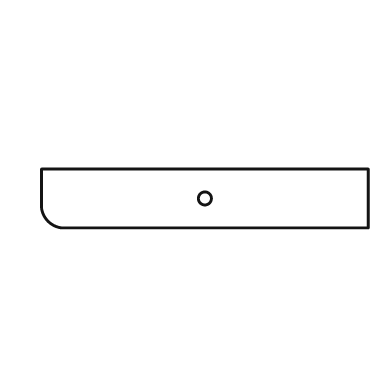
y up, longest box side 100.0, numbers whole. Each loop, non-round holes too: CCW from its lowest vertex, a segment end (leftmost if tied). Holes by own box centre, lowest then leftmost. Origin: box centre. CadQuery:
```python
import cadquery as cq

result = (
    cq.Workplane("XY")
    .moveTo(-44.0, -9.0)
    .lineTo(50.0, -9.0)
    .lineTo(50.0, 9.0)
    .lineTo(-50.0, 9.0)
    .lineTo(-50.0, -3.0)
    .threePointArc((-48.0, -7.0), (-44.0, -9.0))
    .close()
    .moveTo(0.0, 0.0)
    .circle(2.0)
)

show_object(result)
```